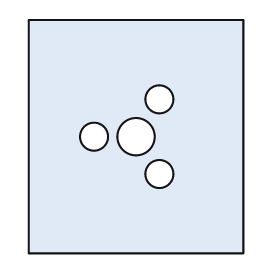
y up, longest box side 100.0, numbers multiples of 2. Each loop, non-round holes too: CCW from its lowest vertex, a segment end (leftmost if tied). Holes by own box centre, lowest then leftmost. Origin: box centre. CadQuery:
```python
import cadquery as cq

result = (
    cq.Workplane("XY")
    .moveTo(-46.0, -50.0)
    .lineTo(46.0, -50.0)
    .lineTo(46.0, 50.0)
    .lineTo(-46.0, 50.0)
    .close()
    .moveTo(10.0, -16.0)
    .circle(6.0)
    .moveTo(-18.0, 0.0)
    .circle(6.0)
    .moveTo(0.0, 0.0)
    .circle(8.0)
    .moveTo(10.0, 16.0)
    .circle(6.0)
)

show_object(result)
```